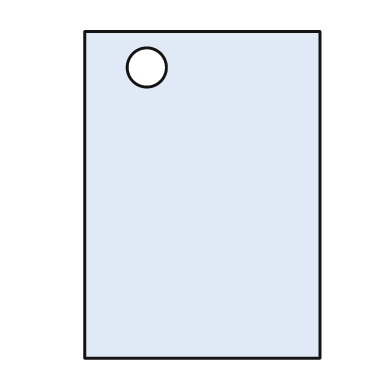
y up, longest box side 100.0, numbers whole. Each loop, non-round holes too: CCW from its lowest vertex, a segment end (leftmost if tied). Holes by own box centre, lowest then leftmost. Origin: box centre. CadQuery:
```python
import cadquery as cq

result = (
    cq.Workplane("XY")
    .moveTo(-36.0, -50.0)
    .lineTo(36.0, -50.0)
    .lineTo(36.0, 50.0)
    .lineTo(-36.0, 50.0)
    .close()
    .moveTo(-17.0, 39.0)
    .circle(6.0)
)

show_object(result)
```